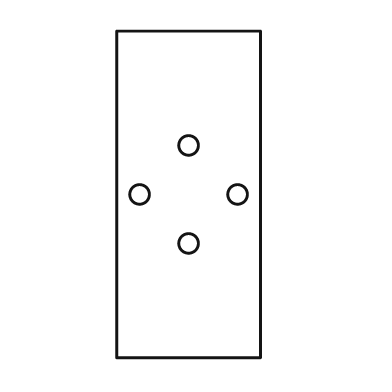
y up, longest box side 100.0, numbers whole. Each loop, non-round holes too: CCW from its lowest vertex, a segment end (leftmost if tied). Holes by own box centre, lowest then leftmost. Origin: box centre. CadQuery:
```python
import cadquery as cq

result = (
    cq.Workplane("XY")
    .moveTo(-22.0, -50.0)
    .lineTo(22.0, -50.0)
    .lineTo(22.0, 50.0)
    .lineTo(-22.0, 50.0)
    .close()
    .moveTo(0.0, -15.0)
    .circle(3.0)
    .moveTo(-15.0, 0.0)
    .circle(3.0)
    .moveTo(15.0, 0.0)
    .circle(3.0)
    .moveTo(0.0, 15.0)
    .circle(3.0)
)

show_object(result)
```